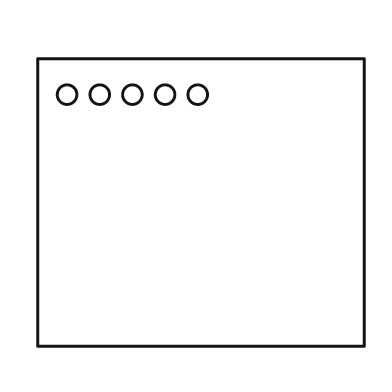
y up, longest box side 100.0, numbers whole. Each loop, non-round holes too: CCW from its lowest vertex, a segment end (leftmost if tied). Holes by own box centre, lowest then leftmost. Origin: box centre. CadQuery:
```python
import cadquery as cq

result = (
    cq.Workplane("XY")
    .moveTo(-50.0, -44.0)
    .lineTo(50.0, -44.0)
    .lineTo(50.0, 44.0)
    .lineTo(-50.0, 44.0)
    .close()
    .moveTo(-41.0, 33.0)
    .circle(3.0)
    .moveTo(-31.0, 33.0)
    .circle(3.0)
    .moveTo(-21.0, 33.0)
    .circle(3.0)
    .moveTo(-11.0, 33.0)
    .circle(3.0)
    .moveTo(-1.0, 33.0)
    .circle(3.0)
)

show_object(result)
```